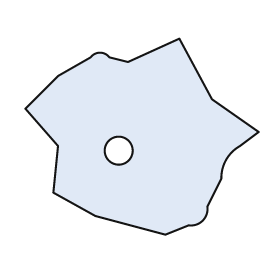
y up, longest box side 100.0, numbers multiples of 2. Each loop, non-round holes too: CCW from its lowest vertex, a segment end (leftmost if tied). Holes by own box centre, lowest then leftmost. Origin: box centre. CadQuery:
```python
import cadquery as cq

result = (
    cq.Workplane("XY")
    .moveTo(10.0, -42.0)
    .lineTo(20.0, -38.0)
    .threePointArc((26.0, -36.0), (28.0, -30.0))
    .lineTo(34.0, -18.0)
    .threePointArc((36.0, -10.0), (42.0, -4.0))
    .lineTo(50.0, 2.0)
    .lineTo(30.0, 16.0)
    .lineTo(16.0, 42.0)
    .lineTo(-6.0, 32.0)
    .lineTo(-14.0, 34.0)
    .threePointArc((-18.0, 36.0), (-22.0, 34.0))
    .lineTo(-36.0, 26.0)
    .lineTo(-50.0, 12.0)
    .lineTo(-36.0, -4.0)
    .lineTo(-38.0, -24.0)
    .lineTo(-20.0, -34.0)
    .close()
    .moveTo(-10.0, -6.0)
    .circle(6.0)
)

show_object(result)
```